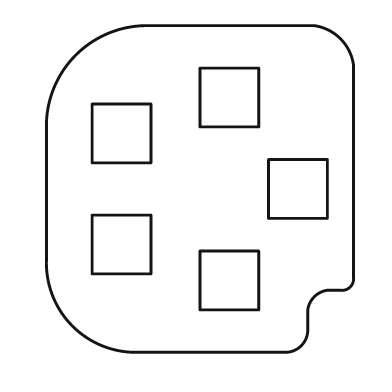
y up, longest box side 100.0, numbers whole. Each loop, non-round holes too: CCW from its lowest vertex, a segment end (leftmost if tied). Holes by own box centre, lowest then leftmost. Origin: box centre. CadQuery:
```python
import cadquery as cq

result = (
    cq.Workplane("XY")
    .moveTo(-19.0, -50.0)
    .lineTo(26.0, -50.0)
    .threePointArc((31.0, -48.0), (33.0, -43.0))
    .lineTo(33.0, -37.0)
    .threePointArc((35.0, -33.0), (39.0, -31.0))
    .lineTo(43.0, -31.0)
    .threePointArc((46.0, -30.0), (47.0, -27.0))
    .lineTo(47.0, 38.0)
    .threePointArc((43.0, 46.0), (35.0, 50.0))
    .lineTo(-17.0, 50.0)
    .threePointArc((-38.0, 41.0), (-47.0, 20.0))
    .lineTo(-47.0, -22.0)
    .threePointArc((-39.0, -42.0), (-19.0, -50.0))
    .close()
    .moveTo(0.0, -37.0)
    .lineTo(18.0, -37.0)
    .lineTo(18.0, -19.0)
    .lineTo(0.0, -19.0)
    .close()
    .moveTo(-33.0, -26.0)
    .lineTo(-15.0, -26.0)
    .lineTo(-15.0, -8.0)
    .lineTo(-33.0, -8.0)
    .close()
    .moveTo(21.0, -9.0)
    .lineTo(39.0, -9.0)
    .lineTo(39.0, 9.0)
    .lineTo(21.0, 9.0)
    .close()
    .moveTo(-33.0, 8.0)
    .lineTo(-15.0, 8.0)
    .lineTo(-15.0, 26.0)
    .lineTo(-33.0, 26.0)
    .close()
    .moveTo(0.0, 19.0)
    .lineTo(18.0, 19.0)
    .lineTo(18.0, 37.0)
    .lineTo(0.0, 37.0)
    .close()
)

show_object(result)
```